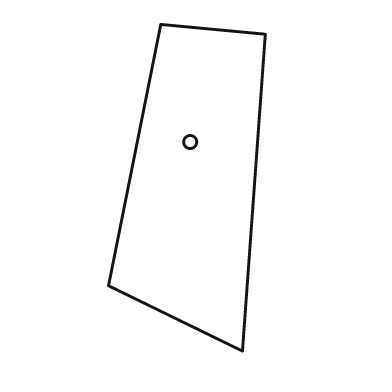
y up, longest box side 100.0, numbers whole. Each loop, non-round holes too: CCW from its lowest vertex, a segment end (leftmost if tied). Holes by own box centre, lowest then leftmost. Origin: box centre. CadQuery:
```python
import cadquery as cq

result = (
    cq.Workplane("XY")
    .moveTo(17.0, -50.0)
    .lineTo(24.0, 47.0)
    .lineTo(-8.0, 50.0)
    .lineTo(-24.0, -30.0)
    .close()
    .moveTo(1.0, 14.0)
    .circle(2.0)
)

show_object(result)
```